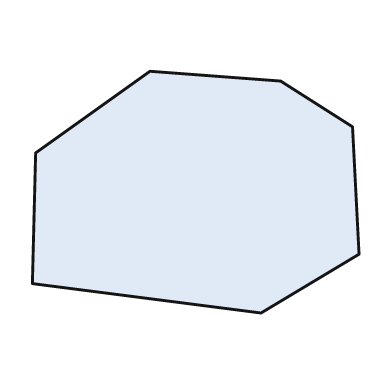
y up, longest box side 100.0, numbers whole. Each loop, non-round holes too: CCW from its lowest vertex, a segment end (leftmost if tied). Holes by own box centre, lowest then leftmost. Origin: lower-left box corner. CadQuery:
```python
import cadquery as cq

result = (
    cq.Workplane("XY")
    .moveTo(70.0, 0.0)
    .lineTo(100.0, 18.0)
    .lineTo(98.0, 57.0)
    .lineTo(76.0, 71.0)
    .lineTo(36.0, 74.0)
    .lineTo(1.0, 49.0)
    .lineTo(0.0, 9.0)
    .close()
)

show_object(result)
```